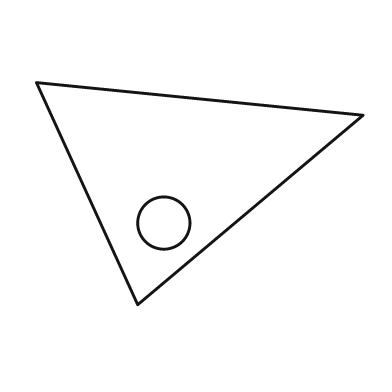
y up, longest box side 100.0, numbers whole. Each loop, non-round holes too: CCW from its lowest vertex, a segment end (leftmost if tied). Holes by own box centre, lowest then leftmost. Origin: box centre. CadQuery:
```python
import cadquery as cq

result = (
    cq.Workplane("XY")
    .moveTo(-19.0, -34.0)
    .lineTo(50.0, 24.0)
    .lineTo(-50.0, 34.0)
    .close()
    .moveTo(-11.0, -9.0)
    .circle(8.0)
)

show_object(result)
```